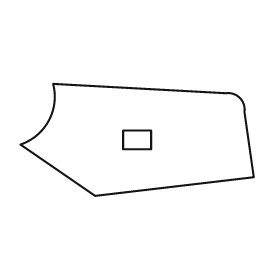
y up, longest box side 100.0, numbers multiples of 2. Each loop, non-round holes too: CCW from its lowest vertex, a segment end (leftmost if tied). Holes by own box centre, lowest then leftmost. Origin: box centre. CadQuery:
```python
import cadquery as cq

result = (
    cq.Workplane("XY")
    .moveTo(-18.0, -24.0)
    .lineTo(50.0, -16.0)
    .lineTo(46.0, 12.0)
    .threePointArc((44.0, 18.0), (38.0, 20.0))
    .lineTo(-36.0, 24.0)
    .threePointArc((-38.0, 8.0), (-50.0, -2.0))
    .close()
    .moveTo(-6.0, -4.0)
    .lineTo(6.0, -4.0)
    .lineTo(6.0, 4.0)
    .lineTo(-6.0, 4.0)
    .close()
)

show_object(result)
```